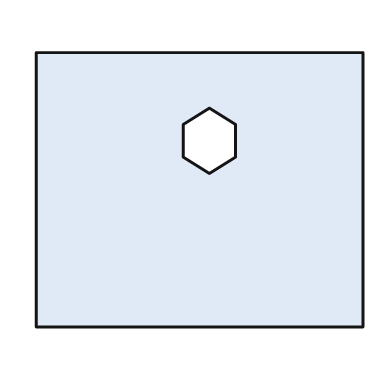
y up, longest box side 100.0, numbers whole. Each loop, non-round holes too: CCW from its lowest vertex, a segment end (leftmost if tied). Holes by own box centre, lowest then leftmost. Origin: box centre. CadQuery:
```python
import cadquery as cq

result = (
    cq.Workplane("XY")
    .moveTo(-50.0, -42.0)
    .lineTo(50.0, -42.0)
    .lineTo(50.0, 42.0)
    .lineTo(-50.0, 42.0)
    .close()
    .moveTo(3.0, 5.0)
    .lineTo(11.0, 10.0)
    .lineTo(11.0, 20.0)
    .lineTo(3.0, 25.0)
    .lineTo(-5.0, 20.0)
    .lineTo(-5.0, 10.0)
    .close()
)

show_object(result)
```